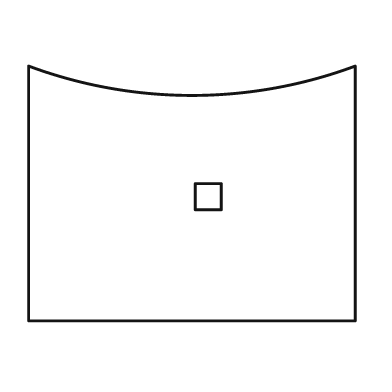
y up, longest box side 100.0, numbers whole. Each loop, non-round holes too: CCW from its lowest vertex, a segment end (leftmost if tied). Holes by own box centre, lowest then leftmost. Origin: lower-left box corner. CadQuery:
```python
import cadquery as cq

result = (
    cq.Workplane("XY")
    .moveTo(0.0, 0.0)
    .lineTo(100.0, 0.0)
    .lineTo(100.0, 78.0)
    .threePointArc((50.0, 69.0), (0.0, 78.0))
    .close()
    .moveTo(51.0, 34.0)
    .lineTo(59.0, 34.0)
    .lineTo(59.0, 42.0)
    .lineTo(51.0, 42.0)
    .close()
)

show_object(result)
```